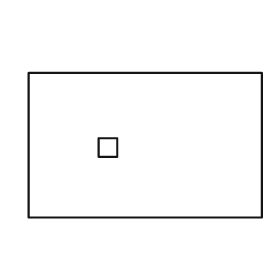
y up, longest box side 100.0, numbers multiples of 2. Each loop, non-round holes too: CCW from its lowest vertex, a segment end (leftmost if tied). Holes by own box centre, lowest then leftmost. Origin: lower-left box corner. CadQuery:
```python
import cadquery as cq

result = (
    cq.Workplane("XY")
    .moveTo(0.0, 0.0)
    .lineTo(100.0, 0.0)
    .lineTo(100.0, 62.0)
    .lineTo(0.0, 62.0)
    .close()
    .moveTo(30.0, 26.0)
    .lineTo(38.0, 26.0)
    .lineTo(38.0, 34.0)
    .lineTo(30.0, 34.0)
    .close()
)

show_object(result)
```